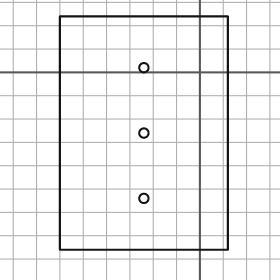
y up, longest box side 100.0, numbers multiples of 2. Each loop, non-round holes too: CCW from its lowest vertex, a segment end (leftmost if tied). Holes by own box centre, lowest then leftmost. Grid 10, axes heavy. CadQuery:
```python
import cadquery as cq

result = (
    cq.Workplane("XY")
    .moveTo(-60.0, -76.0)
    .lineTo(12.0, -76.0)
    .lineTo(12.0, 24.0)
    .lineTo(-60.0, 24.0)
    .close()
    .moveTo(-24.0, -54.0)
    .circle(2.0)
    .moveTo(-24.0, -26.0)
    .circle(2.0)
    .moveTo(-24.0, 2.0)
    .circle(2.0)
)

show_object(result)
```